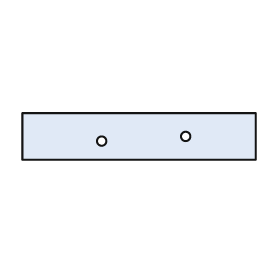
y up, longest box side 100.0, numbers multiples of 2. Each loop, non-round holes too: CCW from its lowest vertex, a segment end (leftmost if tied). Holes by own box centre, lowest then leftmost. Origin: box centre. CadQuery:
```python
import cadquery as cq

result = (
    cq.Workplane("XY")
    .moveTo(-50.0, -10.0)
    .lineTo(50.0, -10.0)
    .lineTo(50.0, 10.0)
    .lineTo(-50.0, 10.0)
    .close()
    .moveTo(-16.0, -2.0)
    .circle(2.0)
    .moveTo(20.0, 0.0)
    .circle(2.0)
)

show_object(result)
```